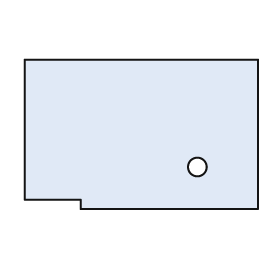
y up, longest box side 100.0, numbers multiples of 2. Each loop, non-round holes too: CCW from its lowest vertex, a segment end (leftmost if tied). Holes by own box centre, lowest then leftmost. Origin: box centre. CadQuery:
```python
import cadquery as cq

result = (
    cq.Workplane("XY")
    .moveTo(-26.0, -32.0)
    .lineTo(50.0, -32.0)
    .lineTo(50.0, 32.0)
    .lineTo(-50.0, 32.0)
    .lineTo(-50.0, -28.0)
    .lineTo(-26.0, -28.0)
    .close()
    .moveTo(24.0, -14.0)
    .circle(4.0)
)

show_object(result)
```